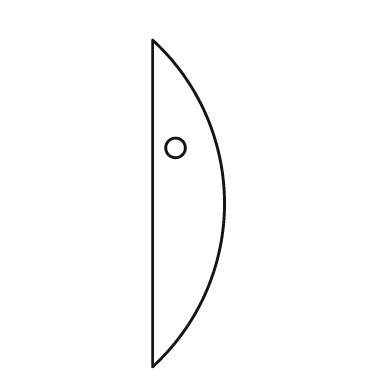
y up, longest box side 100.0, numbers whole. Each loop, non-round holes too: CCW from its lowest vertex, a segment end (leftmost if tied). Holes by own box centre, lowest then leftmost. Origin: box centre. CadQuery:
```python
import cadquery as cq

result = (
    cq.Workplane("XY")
    .moveTo(-11.0, -50.0)
    .threePointArc((11.0, 0.0), (-11.0, 50.0))
    .close()
    .moveTo(-4.0, 17.0)
    .circle(3.0)
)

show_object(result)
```